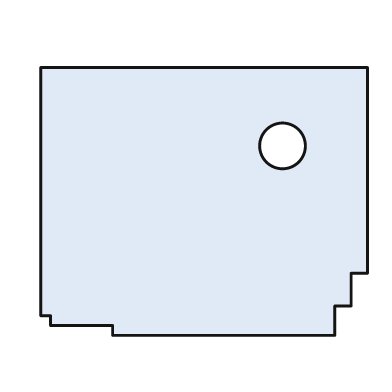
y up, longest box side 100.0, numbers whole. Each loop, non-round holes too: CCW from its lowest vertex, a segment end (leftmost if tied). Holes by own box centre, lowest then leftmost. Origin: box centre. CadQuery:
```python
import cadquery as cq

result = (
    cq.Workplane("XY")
    .moveTo(-28.0, -41.0)
    .lineTo(40.0, -41.0)
    .lineTo(40.0, -32.0)
    .lineTo(45.0, -32.0)
    .lineTo(45.0, -22.0)
    .lineTo(50.0, -22.0)
    .lineTo(50.0, 41.0)
    .lineTo(-50.0, 41.0)
    .lineTo(-50.0, -35.0)
    .lineTo(-47.0, -35.0)
    .lineTo(-47.0, -38.0)
    .lineTo(-28.0, -38.0)
    .close()
    .moveTo(24.0, 17.0)
    .circle(7.0)
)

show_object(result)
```